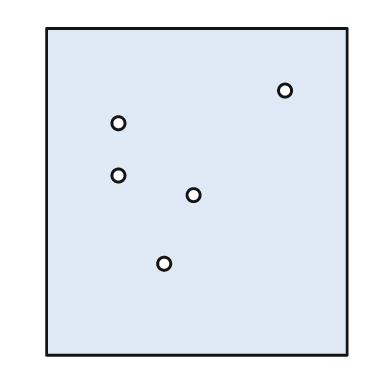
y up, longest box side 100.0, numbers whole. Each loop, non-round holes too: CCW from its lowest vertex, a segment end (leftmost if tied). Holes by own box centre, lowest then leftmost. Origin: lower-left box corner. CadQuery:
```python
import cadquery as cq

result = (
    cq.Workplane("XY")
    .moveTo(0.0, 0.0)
    .lineTo(92.0, 0.0)
    .lineTo(92.0, 100.0)
    .lineTo(0.0, 100.0)
    .close()
    .moveTo(36.0, 28.0)
    .circle(2.0)
    .moveTo(45.0, 49.0)
    .circle(2.0)
    .moveTo(22.0, 55.0)
    .circle(2.0)
    .moveTo(22.0, 71.0)
    .circle(2.0)
    .moveTo(73.0, 81.0)
    .circle(2.0)
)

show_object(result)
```